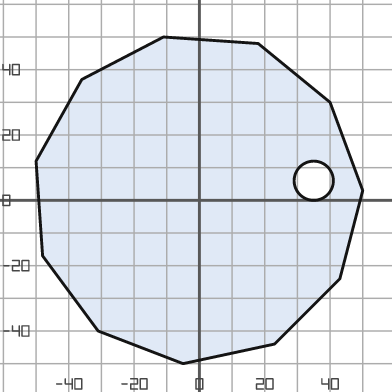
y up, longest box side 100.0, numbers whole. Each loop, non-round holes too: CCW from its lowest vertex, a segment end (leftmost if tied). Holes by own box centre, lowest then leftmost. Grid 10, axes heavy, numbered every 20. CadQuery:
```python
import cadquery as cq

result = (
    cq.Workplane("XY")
    .moveTo(-5.0, -50.0)
    .lineTo(23.0, -44.0)
    .lineTo(43.0, -24.0)
    .lineTo(50.0, 3.0)
    .lineTo(40.0, 30.0)
    .lineTo(18.0, 48.0)
    .lineTo(-11.0, 50.0)
    .lineTo(-36.0, 37.0)
    .lineTo(-50.0, 12.0)
    .lineTo(-48.0, -17.0)
    .lineTo(-31.0, -40.0)
    .close()
    .moveTo(35.0, 6.0)
    .circle(6.0)
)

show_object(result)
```